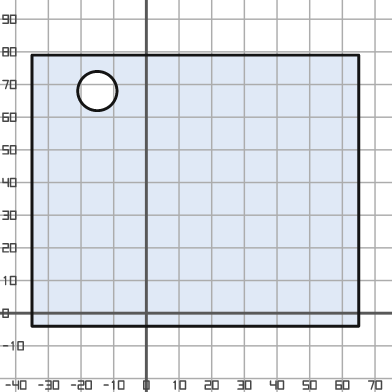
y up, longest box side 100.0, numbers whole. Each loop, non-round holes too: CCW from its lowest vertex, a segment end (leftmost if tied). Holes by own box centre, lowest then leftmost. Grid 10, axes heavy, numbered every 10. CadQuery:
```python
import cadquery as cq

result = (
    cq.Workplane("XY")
    .moveTo(-35.0, -4.0)
    .lineTo(65.0, -4.0)
    .lineTo(65.0, 79.0)
    .lineTo(-35.0, 79.0)
    .close()
    .moveTo(-15.0, 68.0)
    .circle(6.0)
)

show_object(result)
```